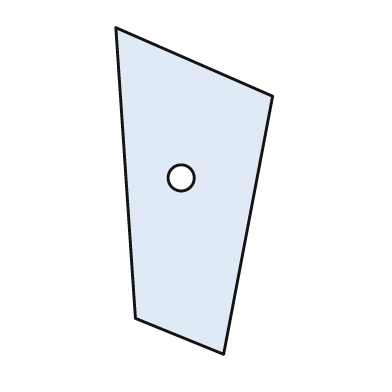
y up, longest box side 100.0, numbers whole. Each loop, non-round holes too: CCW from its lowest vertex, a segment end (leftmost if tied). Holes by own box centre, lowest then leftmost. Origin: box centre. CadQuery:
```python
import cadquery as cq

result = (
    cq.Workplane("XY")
    .moveTo(9.0, -50.0)
    .lineTo(24.0, 29.0)
    .lineTo(-24.0, 50.0)
    .lineTo(-18.0, -39.0)
    .close()
    .moveTo(-4.0, 4.0)
    .circle(4.0)
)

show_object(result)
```